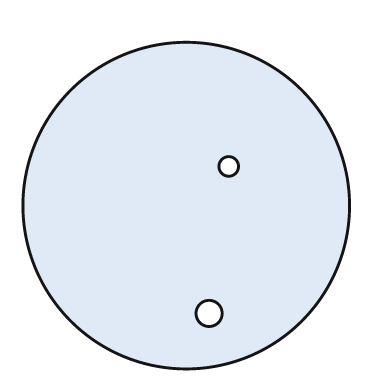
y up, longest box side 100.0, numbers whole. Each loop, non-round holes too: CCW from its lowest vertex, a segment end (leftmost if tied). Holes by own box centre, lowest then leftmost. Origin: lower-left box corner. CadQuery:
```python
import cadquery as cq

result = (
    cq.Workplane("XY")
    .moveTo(50.0, 50.0)
    .circle(50.0)
    .moveTo(57.0, 17.0)
    .circle(4.0)
    .moveTo(63.0, 62.0)
    .circle(3.0)
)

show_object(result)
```